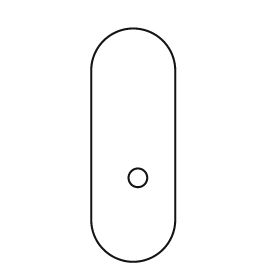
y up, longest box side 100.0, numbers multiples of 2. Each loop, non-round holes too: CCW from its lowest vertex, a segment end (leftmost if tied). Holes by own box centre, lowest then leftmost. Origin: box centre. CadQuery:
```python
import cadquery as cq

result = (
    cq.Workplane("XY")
    .moveTo(-18.0, -32.0)
    .threePointArc((0.0, -50.0), (18.0, -32.0))
    .lineTo(18.0, 32.0)
    .threePointArc((0.0, 50.0), (-18.0, 32.0))
    .close()
    .moveTo(2.0, -14.0)
    .circle(4.0)
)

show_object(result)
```